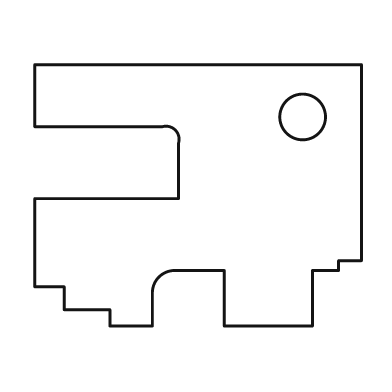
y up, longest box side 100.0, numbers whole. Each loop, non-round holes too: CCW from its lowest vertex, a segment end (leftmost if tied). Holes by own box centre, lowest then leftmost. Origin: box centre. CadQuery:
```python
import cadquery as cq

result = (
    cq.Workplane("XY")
    .moveTo(-27.0, -40.0)
    .lineTo(-14.0, -40.0)
    .lineTo(-14.0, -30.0)
    .threePointArc((-12.0, -25.0), (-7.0, -23.0))
    .lineTo(8.0, -23.0)
    .lineTo(8.0, -40.0)
    .lineTo(35.0, -40.0)
    .lineTo(35.0, -23.0)
    .lineTo(43.0, -23.0)
    .lineTo(43.0, -20.0)
    .lineTo(50.0, -20.0)
    .lineTo(50.0, 40.0)
    .lineTo(-50.0, 40.0)
    .lineTo(-50.0, 21.0)
    .lineTo(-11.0, 21.0)
    .threePointArc((-7.0, 20.0), (-6.0, 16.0))
    .lineTo(-6.0, -1.0)
    .lineTo(-50.0, -1.0)
    .lineTo(-50.0, -28.0)
    .lineTo(-41.0, -28.0)
    .lineTo(-41.0, -35.0)
    .lineTo(-27.0, -35.0)
    .close()
    .moveTo(32.0, 24.0)
    .circle(7.0)
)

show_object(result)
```